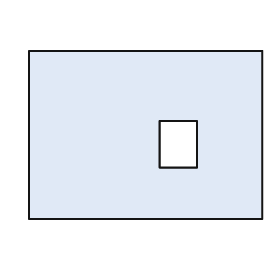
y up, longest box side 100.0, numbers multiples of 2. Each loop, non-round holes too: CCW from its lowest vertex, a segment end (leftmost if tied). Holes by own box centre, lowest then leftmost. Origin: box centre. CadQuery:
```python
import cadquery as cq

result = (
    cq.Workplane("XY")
    .moveTo(-50.0, -36.0)
    .lineTo(50.0, -36.0)
    .lineTo(50.0, 36.0)
    .lineTo(-50.0, 36.0)
    .close()
    .moveTo(6.0, -14.0)
    .lineTo(22.0, -14.0)
    .lineTo(22.0, 6.0)
    .lineTo(6.0, 6.0)
    .close()
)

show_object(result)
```